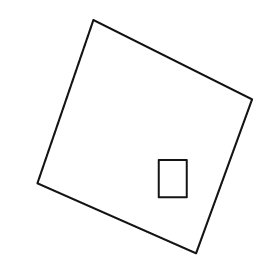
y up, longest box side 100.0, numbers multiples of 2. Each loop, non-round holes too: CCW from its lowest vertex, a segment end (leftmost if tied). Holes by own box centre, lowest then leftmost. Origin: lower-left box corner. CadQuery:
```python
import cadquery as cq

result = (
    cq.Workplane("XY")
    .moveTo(68.0, 0.0)
    .lineTo(92.0, 66.0)
    .lineTo(24.0, 100.0)
    .lineTo(0.0, 30.0)
    .close()
    .moveTo(52.0, 24.0)
    .lineTo(64.0, 24.0)
    .lineTo(64.0, 40.0)
    .lineTo(52.0, 40.0)
    .close()
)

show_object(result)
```